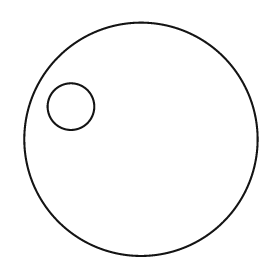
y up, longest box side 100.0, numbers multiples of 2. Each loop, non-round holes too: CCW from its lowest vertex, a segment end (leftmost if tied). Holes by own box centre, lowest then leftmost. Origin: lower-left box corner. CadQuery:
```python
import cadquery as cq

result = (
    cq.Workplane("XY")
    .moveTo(50.0, 50.0)
    .circle(50.0)
    .moveTo(20.0, 64.0)
    .circle(10.0)
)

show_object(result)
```